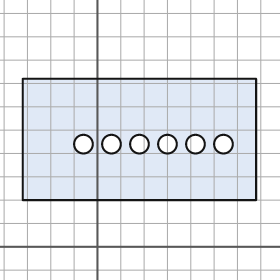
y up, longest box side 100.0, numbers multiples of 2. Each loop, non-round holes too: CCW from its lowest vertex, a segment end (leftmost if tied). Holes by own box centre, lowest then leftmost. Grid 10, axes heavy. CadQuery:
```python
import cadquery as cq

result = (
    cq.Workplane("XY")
    .moveTo(-32.0, 20.0)
    .lineTo(68.0, 20.0)
    .lineTo(68.0, 72.0)
    .lineTo(-32.0, 72.0)
    .close()
    .moveTo(-6.0, 44.0)
    .circle(4.0)
    .moveTo(6.0, 44.0)
    .circle(4.0)
    .moveTo(18.0, 44.0)
    .circle(4.0)
    .moveTo(30.0, 44.0)
    .circle(4.0)
    .moveTo(42.0, 44.0)
    .circle(4.0)
    .moveTo(54.0, 44.0)
    .circle(4.0)
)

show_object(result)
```